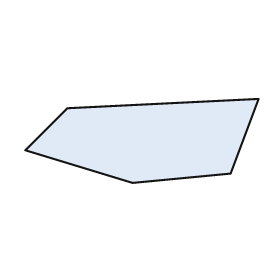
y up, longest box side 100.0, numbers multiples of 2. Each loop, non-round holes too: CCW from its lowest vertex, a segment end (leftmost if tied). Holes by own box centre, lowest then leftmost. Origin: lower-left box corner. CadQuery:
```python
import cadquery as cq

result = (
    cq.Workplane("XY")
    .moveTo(46.0, 0.0)
    .lineTo(88.0, 4.0)
    .lineTo(100.0, 36.0)
    .lineTo(18.0, 32.0)
    .lineTo(0.0, 14.0)
    .close()
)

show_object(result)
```